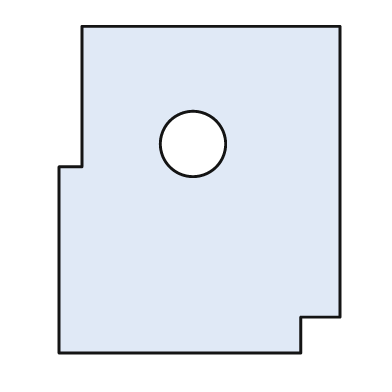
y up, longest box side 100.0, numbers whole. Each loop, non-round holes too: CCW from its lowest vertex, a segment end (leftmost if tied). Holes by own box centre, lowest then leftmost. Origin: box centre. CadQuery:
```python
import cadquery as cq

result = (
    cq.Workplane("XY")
    .moveTo(-43.0, -50.0)
    .lineTo(31.0, -50.0)
    .lineTo(31.0, -39.0)
    .lineTo(43.0, -39.0)
    .lineTo(43.0, 50.0)
    .lineTo(-36.0, 50.0)
    .lineTo(-36.0, 7.0)
    .lineTo(-43.0, 7.0)
    .close()
    .moveTo(-2.0, 14.0)
    .circle(10.0)
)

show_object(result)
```